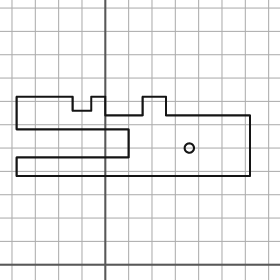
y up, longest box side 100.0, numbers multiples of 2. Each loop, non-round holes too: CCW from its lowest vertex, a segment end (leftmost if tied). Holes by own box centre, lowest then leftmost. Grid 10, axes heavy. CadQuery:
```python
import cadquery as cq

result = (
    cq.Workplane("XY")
    .moveTo(-38.0, 38.0)
    .lineTo(62.0, 38.0)
    .lineTo(62.0, 64.0)
    .lineTo(26.0, 64.0)
    .lineTo(26.0, 72.0)
    .lineTo(16.0, 72.0)
    .lineTo(16.0, 64.0)
    .lineTo(0.0, 64.0)
    .lineTo(0.0, 72.0)
    .lineTo(-6.0, 72.0)
    .lineTo(-6.0, 66.0)
    .lineTo(-14.0, 66.0)
    .lineTo(-14.0, 72.0)
    .lineTo(-38.0, 72.0)
    .lineTo(-38.0, 58.0)
    .lineTo(10.0, 58.0)
    .lineTo(10.0, 46.0)
    .lineTo(-38.0, 46.0)
    .close()
    .moveTo(36.0, 50.0)
    .circle(2.0)
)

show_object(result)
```